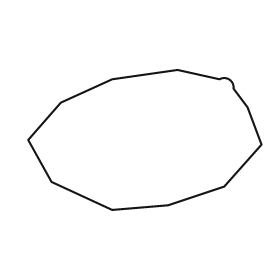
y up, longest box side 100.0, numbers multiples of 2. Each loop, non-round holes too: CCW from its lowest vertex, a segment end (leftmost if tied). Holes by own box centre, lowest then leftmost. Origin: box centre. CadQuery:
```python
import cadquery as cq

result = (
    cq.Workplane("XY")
    .moveTo(-14.0, -30.0)
    .lineTo(10.0, -28.0)
    .lineTo(34.0, -20.0)
    .lineTo(50.0, -2.0)
    .lineTo(44.0, 14.0)
    .lineTo(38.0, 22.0)
    .threePointArc((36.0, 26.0), (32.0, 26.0))
    .lineTo(14.0, 30.0)
    .lineTo(-14.0, 26.0)
    .lineTo(-36.0, 16.0)
    .lineTo(-50.0, 0.0)
    .lineTo(-40.0, -18.0)
    .close()
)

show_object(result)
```